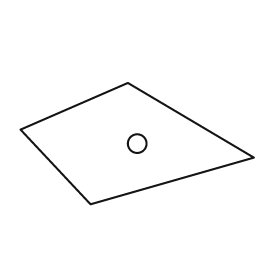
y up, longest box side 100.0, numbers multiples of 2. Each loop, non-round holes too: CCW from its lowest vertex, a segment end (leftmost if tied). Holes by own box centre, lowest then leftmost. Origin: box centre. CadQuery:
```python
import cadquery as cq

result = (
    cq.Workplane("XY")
    .moveTo(-20.0, -26.0)
    .lineTo(50.0, -6.0)
    .lineTo(-4.0, 26.0)
    .lineTo(-50.0, 6.0)
    .close()
    .moveTo(0.0, 0.0)
    .circle(4.0)
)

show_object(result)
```